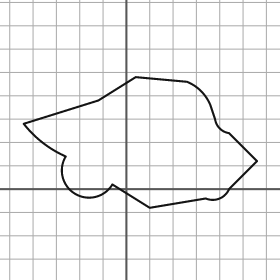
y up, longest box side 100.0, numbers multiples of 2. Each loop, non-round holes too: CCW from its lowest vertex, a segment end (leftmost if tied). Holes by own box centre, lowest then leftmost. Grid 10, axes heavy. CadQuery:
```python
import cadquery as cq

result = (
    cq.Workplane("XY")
    .moveTo(10.0, -8.0)
    .lineTo(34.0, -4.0)
    .threePointArc((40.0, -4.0), (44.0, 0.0))
    .lineTo(56.0, 12.0)
    .lineTo(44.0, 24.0)
    .threePointArc((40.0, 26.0), (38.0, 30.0))
    .lineTo(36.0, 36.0)
    .threePointArc((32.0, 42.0), (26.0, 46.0))
    .lineTo(4.0, 48.0)
    .lineTo(-12.0, 38.0)
    .lineTo(-44.0, 28.0)
    .threePointArc((-36.0, 20.0), (-26.0, 14.0))
    .threePointArc((-22.0, -2.0), (-6.0, 2.0))
    .close()
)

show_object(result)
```